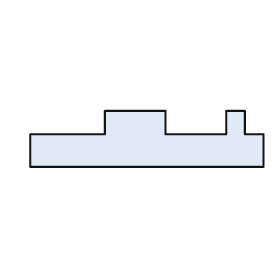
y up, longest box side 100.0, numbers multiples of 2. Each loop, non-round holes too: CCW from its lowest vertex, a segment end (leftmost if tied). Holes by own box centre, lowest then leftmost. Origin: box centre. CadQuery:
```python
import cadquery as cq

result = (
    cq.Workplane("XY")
    .moveTo(-50.0, -12.0)
    .lineTo(50.0, -12.0)
    .lineTo(50.0, 2.0)
    .lineTo(42.0, 2.0)
    .lineTo(42.0, 12.0)
    .lineTo(34.0, 12.0)
    .lineTo(34.0, 2.0)
    .lineTo(8.0, 2.0)
    .lineTo(8.0, 12.0)
    .lineTo(-18.0, 12.0)
    .lineTo(-18.0, 2.0)
    .lineTo(-50.0, 2.0)
    .close()
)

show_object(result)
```